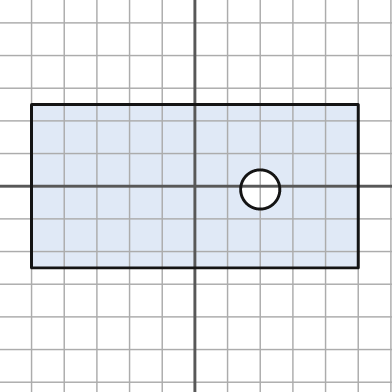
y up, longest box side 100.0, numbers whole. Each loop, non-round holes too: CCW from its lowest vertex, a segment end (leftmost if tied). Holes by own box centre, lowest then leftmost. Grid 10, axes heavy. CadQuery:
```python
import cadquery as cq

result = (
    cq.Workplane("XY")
    .moveTo(-50.0, -25.0)
    .lineTo(50.0, -25.0)
    .lineTo(50.0, 25.0)
    .lineTo(-50.0, 25.0)
    .close()
    .moveTo(20.0, -1.0)
    .circle(6.0)
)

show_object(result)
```